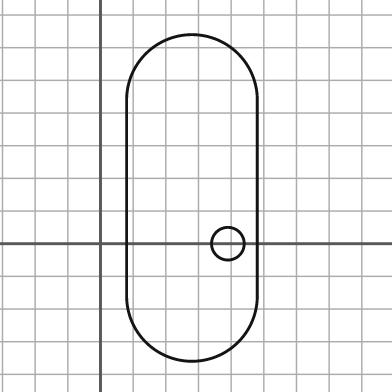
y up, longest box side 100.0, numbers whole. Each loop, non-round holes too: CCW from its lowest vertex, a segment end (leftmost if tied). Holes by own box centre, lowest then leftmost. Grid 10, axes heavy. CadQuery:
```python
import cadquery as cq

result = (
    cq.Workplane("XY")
    .moveTo(8.0, -16.0)
    .threePointArc((28.0, -36.0), (48.0, -16.0))
    .lineTo(48.0, 44.0)
    .threePointArc((28.0, 64.0), (8.0, 44.0))
    .close()
    .moveTo(39.0, 0.0)
    .circle(5.0)
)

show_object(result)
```